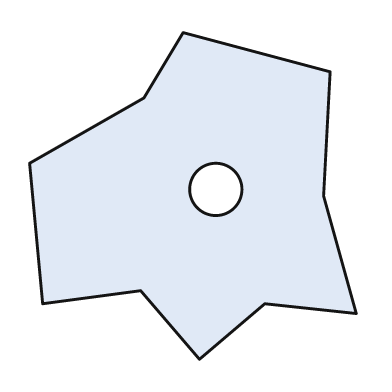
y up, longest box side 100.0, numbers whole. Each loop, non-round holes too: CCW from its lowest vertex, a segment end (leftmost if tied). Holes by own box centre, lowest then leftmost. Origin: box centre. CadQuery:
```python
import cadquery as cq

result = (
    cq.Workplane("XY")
    .moveTo(2.0, -50.0)
    .lineTo(22.0, -33.0)
    .lineTo(50.0, -36.0)
    .lineTo(40.0, 0.0)
    .lineTo(42.0, 38.0)
    .lineTo(-3.0, 50.0)
    .lineTo(-15.0, 30.0)
    .lineTo(-50.0, 10.0)
    .lineTo(-46.0, -33.0)
    .lineTo(-16.0, -29.0)
    .close()
    .moveTo(7.0, 2.0)
    .circle(8.0)
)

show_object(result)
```